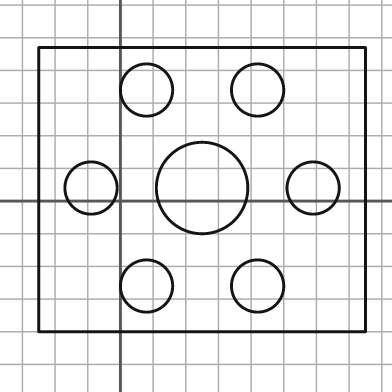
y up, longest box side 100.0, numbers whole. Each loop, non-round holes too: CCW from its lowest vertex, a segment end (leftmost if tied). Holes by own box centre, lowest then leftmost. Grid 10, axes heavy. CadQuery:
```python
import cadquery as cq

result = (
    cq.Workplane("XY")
    .moveTo(-25.0, -40.0)
    .lineTo(75.0, -40.0)
    .lineTo(75.0, 47.0)
    .lineTo(-25.0, 47.0)
    .close()
    .moveTo(8.0, -26.0)
    .circle(8.0)
    .moveTo(42.0, -26.0)
    .circle(8.0)
    .moveTo(-9.0, 4.0)
    .circle(8.0)
    .moveTo(25.0, 4.0)
    .circle(14.0)
    .moveTo(59.0, 4.0)
    .circle(8.0)
    .moveTo(8.0, 34.0)
    .circle(8.0)
    .moveTo(42.0, 34.0)
    .circle(8.0)
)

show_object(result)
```